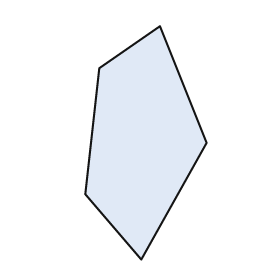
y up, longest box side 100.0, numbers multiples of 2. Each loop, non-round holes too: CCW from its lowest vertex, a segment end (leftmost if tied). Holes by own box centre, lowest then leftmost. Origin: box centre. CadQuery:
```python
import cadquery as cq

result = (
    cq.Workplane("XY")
    .moveTo(-2.0, -50.0)
    .lineTo(26.0, 0.0)
    .lineTo(6.0, 50.0)
    .lineTo(-20.0, 32.0)
    .lineTo(-26.0, -22.0)
    .close()
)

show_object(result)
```